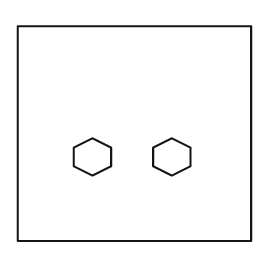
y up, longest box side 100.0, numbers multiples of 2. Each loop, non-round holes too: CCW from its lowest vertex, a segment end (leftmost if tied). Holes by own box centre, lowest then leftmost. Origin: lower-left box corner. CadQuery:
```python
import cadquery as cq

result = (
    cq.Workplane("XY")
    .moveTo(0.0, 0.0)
    .lineTo(100.0, 0.0)
    .lineTo(100.0, 92.0)
    .lineTo(0.0, 92.0)
    .close()
    .moveTo(32.0, 28.0)
    .lineTo(40.0, 32.0)
    .lineTo(40.0, 40.0)
    .lineTo(32.0, 44.0)
    .lineTo(24.0, 40.0)
    .lineTo(24.0, 32.0)
    .close()
    .moveTo(66.0, 28.0)
    .lineTo(74.0, 32.0)
    .lineTo(74.0, 40.0)
    .lineTo(66.0, 44.0)
    .lineTo(58.0, 40.0)
    .lineTo(58.0, 32.0)
    .close()
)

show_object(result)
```